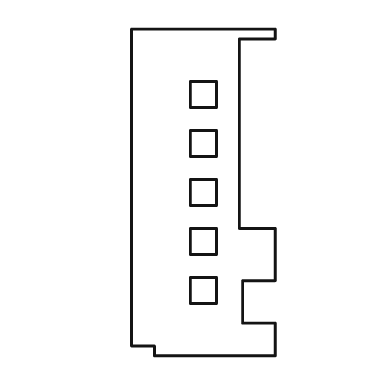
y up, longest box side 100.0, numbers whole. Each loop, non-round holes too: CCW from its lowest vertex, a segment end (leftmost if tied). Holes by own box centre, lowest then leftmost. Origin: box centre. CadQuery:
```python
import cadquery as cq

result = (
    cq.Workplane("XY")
    .moveTo(-15.0, -50.0)
    .lineTo(22.0, -50.0)
    .lineTo(22.0, -40.0)
    .lineTo(12.0, -40.0)
    .lineTo(12.0, -27.0)
    .lineTo(22.0, -27.0)
    .lineTo(22.0, -11.0)
    .lineTo(11.0, -11.0)
    .lineTo(11.0, 47.0)
    .lineTo(22.0, 47.0)
    .lineTo(22.0, 50.0)
    .lineTo(-22.0, 50.0)
    .lineTo(-22.0, -47.0)
    .lineTo(-15.0, -47.0)
    .close()
    .moveTo(-4.0, -34.0)
    .lineTo(4.0, -34.0)
    .lineTo(4.0, -26.0)
    .lineTo(-4.0, -26.0)
    .close()
    .moveTo(-4.0, -19.0)
    .lineTo(4.0, -19.0)
    .lineTo(4.0, -11.0)
    .lineTo(-4.0, -11.0)
    .close()
    .moveTo(-4.0, -4.0)
    .lineTo(4.0, -4.0)
    .lineTo(4.0, 4.0)
    .lineTo(-4.0, 4.0)
    .close()
    .moveTo(-4.0, 11.0)
    .lineTo(4.0, 11.0)
    .lineTo(4.0, 19.0)
    .lineTo(-4.0, 19.0)
    .close()
    .moveTo(-4.0, 26.0)
    .lineTo(4.0, 26.0)
    .lineTo(4.0, 34.0)
    .lineTo(-4.0, 34.0)
    .close()
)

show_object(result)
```